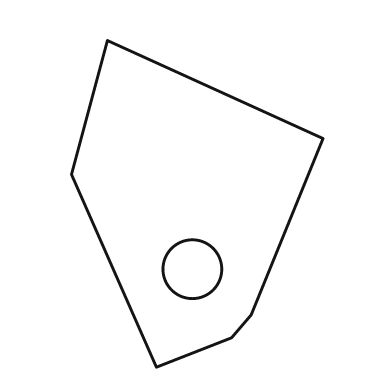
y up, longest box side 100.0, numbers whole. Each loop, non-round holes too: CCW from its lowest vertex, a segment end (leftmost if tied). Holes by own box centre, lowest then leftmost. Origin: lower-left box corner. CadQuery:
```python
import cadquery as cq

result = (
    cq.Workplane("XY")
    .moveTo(26.0, 0.0)
    .lineTo(49.0, 9.0)
    .lineTo(55.0, 16.0)
    .lineTo(77.0, 70.0)
    .lineTo(11.0, 100.0)
    .lineTo(0.0, 59.0)
    .close()
    .moveTo(37.0, 30.0)
    .circle(9.0)
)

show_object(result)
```